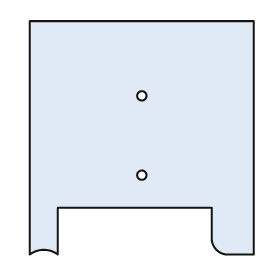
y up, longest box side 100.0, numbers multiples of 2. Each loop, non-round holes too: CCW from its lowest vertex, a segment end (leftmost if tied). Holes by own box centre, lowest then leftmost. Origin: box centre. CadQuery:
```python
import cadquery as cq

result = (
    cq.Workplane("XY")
    .moveTo(-48.0, -50.0)
    .threePointArc((-42.0, -48.0), (-36.0, -50.0))
    .lineTo(-36.0, -30.0)
    .lineTo(30.0, -30.0)
    .lineTo(30.0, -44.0)
    .threePointArc((32.0, -48.0), (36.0, -50.0))
    .lineTo(48.0, -50.0)
    .lineTo(48.0, 50.0)
    .lineTo(-48.0, 50.0)
    .close()
    .moveTo(0.0, -16.0)
    .circle(2.0)
    .moveTo(0.0, 18.0)
    .circle(2.0)
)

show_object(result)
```